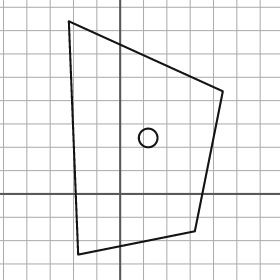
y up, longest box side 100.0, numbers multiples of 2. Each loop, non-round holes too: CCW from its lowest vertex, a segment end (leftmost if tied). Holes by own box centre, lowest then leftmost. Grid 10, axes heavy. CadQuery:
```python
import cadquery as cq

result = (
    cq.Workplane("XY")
    .moveTo(-18.0, -26.0)
    .lineTo(32.0, -16.0)
    .lineTo(44.0, 44.0)
    .lineTo(-22.0, 74.0)
    .close()
    .moveTo(12.0, 24.0)
    .circle(4.0)
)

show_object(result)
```